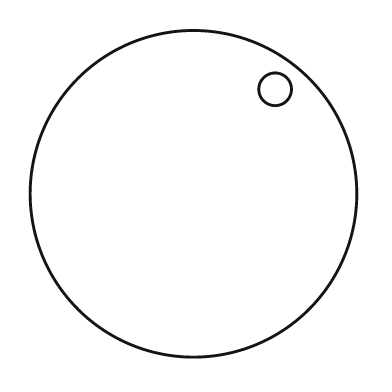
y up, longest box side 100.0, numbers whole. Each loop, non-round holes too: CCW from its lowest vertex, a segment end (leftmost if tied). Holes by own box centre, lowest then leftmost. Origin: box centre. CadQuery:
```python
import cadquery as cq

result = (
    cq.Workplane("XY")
    .moveTo(0.0, 0.0)
    .circle(50.0)
    .moveTo(25.0, 32.0)
    .circle(5.0)
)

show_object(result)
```